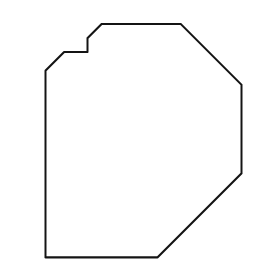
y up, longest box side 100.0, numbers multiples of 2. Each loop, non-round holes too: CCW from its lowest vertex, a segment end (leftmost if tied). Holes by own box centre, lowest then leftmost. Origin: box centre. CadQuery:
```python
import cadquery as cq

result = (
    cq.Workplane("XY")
    .moveTo(-42.0, -50.0)
    .lineTo(6.0, -50.0)
    .lineTo(42.0, -14.0)
    .lineTo(42.0, 24.0)
    .lineTo(16.0, 50.0)
    .lineTo(-18.0, 50.0)
    .lineTo(-24.0, 44.0)
    .lineTo(-24.0, 38.0)
    .lineTo(-34.0, 38.0)
    .lineTo(-42.0, 30.0)
    .close()
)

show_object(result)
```